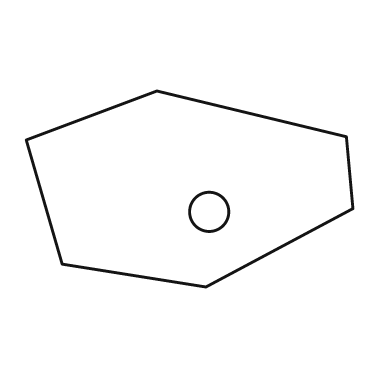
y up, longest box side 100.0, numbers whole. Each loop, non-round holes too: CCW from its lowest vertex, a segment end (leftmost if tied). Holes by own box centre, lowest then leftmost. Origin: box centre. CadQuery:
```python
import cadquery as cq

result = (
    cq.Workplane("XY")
    .moveTo(5.0, -30.0)
    .lineTo(50.0, -6.0)
    .lineTo(48.0, 16.0)
    .lineTo(-10.0, 30.0)
    .lineTo(-50.0, 15.0)
    .lineTo(-39.0, -23.0)
    .close()
    .moveTo(6.0, -7.0)
    .circle(6.0)
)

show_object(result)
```